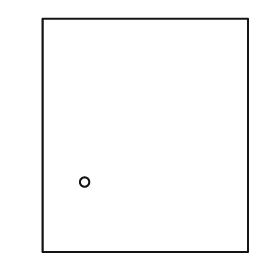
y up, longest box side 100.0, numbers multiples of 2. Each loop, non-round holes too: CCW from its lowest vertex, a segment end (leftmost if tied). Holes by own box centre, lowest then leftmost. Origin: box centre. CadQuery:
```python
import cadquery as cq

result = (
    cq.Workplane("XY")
    .moveTo(-44.0, -50.0)
    .lineTo(44.0, -50.0)
    .lineTo(44.0, 50.0)
    .lineTo(-44.0, 50.0)
    .close()
    .moveTo(-26.0, -20.0)
    .circle(2.0)
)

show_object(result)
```